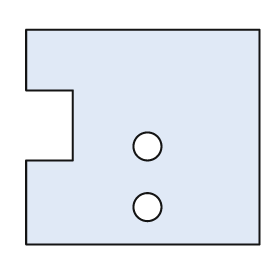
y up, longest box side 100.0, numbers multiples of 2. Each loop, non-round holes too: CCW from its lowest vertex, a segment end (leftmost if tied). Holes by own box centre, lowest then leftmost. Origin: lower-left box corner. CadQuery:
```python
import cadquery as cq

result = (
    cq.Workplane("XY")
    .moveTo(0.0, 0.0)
    .lineTo(100.0, 0.0)
    .lineTo(100.0, 92.0)
    .lineTo(0.0, 92.0)
    .lineTo(0.0, 66.0)
    .lineTo(20.0, 66.0)
    .lineTo(20.0, 36.0)
    .lineTo(0.0, 36.0)
    .close()
    .moveTo(52.0, 16.0)
    .circle(6.0)
    .moveTo(52.0, 42.0)
    .circle(6.0)
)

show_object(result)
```